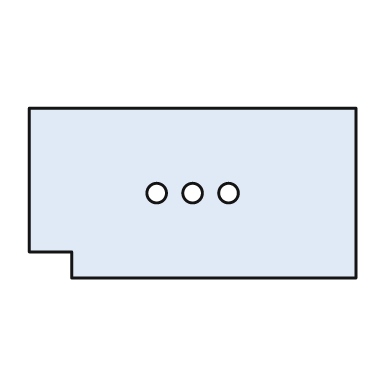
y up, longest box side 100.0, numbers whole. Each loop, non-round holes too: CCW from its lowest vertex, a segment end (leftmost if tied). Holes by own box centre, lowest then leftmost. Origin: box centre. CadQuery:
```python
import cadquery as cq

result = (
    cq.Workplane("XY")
    .moveTo(-37.0, -26.0)
    .lineTo(50.0, -26.0)
    .lineTo(50.0, 26.0)
    .lineTo(-50.0, 26.0)
    .lineTo(-50.0, -18.0)
    .lineTo(-37.0, -18.0)
    .close()
    .moveTo(-11.0, 0.0)
    .circle(3.0)
    .moveTo(0.0, 0.0)
    .circle(3.0)
    .moveTo(11.0, 0.0)
    .circle(3.0)
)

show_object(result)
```